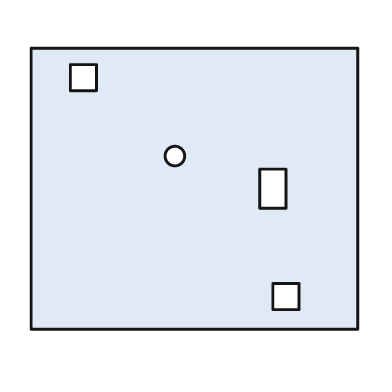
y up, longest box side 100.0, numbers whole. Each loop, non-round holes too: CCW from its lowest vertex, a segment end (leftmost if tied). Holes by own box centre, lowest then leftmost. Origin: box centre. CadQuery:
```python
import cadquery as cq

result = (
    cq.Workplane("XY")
    .moveTo(-50.0, -43.0)
    .lineTo(50.0, -43.0)
    .lineTo(50.0, 43.0)
    .lineTo(-50.0, 43.0)
    .close()
    .moveTo(24.0, -37.0)
    .lineTo(32.0, -37.0)
    .lineTo(32.0, -29.0)
    .lineTo(24.0, -29.0)
    .close()
    .moveTo(20.0, -6.0)
    .lineTo(28.0, -6.0)
    .lineTo(28.0, 6.0)
    .lineTo(20.0, 6.0)
    .close()
    .moveTo(-6.0, 10.0)
    .circle(3.0)
    .moveTo(-38.0, 30.0)
    .lineTo(-30.0, 30.0)
    .lineTo(-30.0, 38.0)
    .lineTo(-38.0, 38.0)
    .close()
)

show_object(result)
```